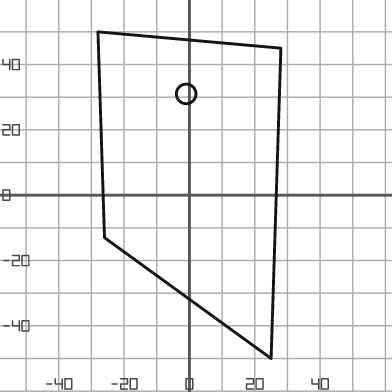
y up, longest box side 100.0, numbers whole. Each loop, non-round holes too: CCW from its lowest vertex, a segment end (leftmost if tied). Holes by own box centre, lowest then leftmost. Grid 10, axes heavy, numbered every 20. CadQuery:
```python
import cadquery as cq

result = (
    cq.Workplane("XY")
    .moveTo(25.0, -50.0)
    .lineTo(28.0, 45.0)
    .lineTo(-28.0, 50.0)
    .lineTo(-26.0, -13.0)
    .close()
    .moveTo(-1.0, 31.0)
    .circle(3.0)
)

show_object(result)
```